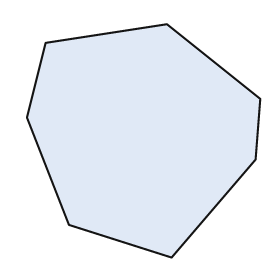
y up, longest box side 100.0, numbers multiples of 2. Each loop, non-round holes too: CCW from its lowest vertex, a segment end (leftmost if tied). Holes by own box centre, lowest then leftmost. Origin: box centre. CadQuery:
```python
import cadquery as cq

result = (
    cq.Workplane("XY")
    .moveTo(12.0, -50.0)
    .lineTo(48.0, -8.0)
    .lineTo(50.0, 18.0)
    .lineTo(10.0, 50.0)
    .lineTo(-42.0, 42.0)
    .lineTo(-50.0, 10.0)
    .lineTo(-32.0, -36.0)
    .close()
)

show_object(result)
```